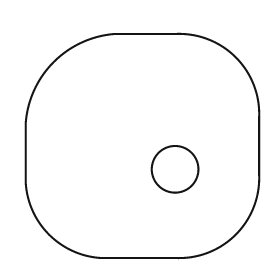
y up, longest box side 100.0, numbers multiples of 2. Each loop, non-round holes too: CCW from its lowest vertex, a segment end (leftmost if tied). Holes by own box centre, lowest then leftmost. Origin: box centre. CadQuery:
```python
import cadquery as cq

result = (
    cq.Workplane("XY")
    .moveTo(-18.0, -48.0)
    .lineTo(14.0, -48.0)
    .threePointArc((40.0, -38.0), (50.0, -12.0))
    .lineTo(50.0, 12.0)
    .threePointArc((40.0, 38.0), (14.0, 48.0))
    .lineTo(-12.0, 48.0)
    .threePointArc((-38.0, 36.0), (-50.0, 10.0))
    .lineTo(-50.0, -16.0)
    .threePointArc((-40.0, -38.0), (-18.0, -48.0))
    .close()
    .moveTo(14.0, -10.0)
    .circle(10.0)
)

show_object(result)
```